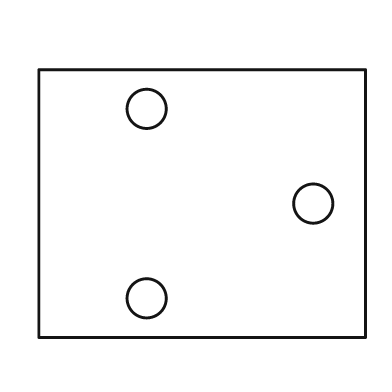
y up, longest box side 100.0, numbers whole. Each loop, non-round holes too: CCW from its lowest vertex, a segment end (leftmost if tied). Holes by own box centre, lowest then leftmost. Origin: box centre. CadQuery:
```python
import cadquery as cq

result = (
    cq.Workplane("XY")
    .moveTo(-50.0, -41.0)
    .lineTo(50.0, -41.0)
    .lineTo(50.0, 41.0)
    .lineTo(-50.0, 41.0)
    .close()
    .moveTo(-17.0, -29.0)
    .circle(6.0)
    .moveTo(34.0, 0.0)
    .circle(6.0)
    .moveTo(-17.0, 29.0)
    .circle(6.0)
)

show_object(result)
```